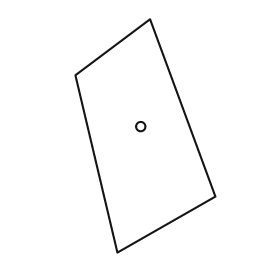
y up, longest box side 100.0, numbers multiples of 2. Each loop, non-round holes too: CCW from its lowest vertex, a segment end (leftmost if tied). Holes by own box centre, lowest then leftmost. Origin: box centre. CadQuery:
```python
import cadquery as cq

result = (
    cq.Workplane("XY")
    .moveTo(-12.0, -50.0)
    .lineTo(30.0, -26.0)
    .lineTo(2.0, 50.0)
    .lineTo(-30.0, 26.0)
    .close()
    .moveTo(-2.0, 4.0)
    .circle(2.0)
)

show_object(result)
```